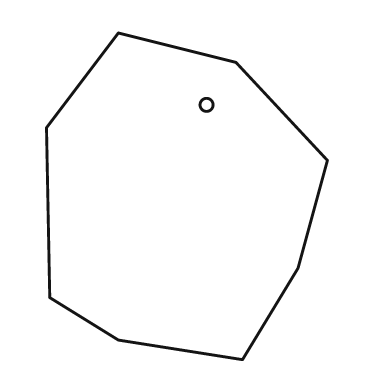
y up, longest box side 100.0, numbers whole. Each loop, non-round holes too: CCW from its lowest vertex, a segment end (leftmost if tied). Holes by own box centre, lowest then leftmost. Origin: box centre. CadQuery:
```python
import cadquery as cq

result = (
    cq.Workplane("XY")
    .moveTo(17.0, -50.0)
    .lineTo(34.0, -22.0)
    .lineTo(43.0, 11.0)
    .lineTo(15.0, 41.0)
    .lineTo(-21.0, 50.0)
    .lineTo(-43.0, 21.0)
    .lineTo(-42.0, -31.0)
    .lineTo(-21.0, -44.0)
    .close()
    .moveTo(6.0, 28.0)
    .circle(2.0)
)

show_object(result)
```